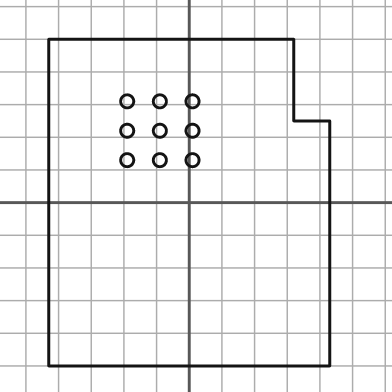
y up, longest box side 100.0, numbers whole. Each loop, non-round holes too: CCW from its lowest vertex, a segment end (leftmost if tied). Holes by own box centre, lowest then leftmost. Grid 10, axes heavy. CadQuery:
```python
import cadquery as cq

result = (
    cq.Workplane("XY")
    .moveTo(-43.0, -50.0)
    .lineTo(43.0, -50.0)
    .lineTo(43.0, 25.0)
    .lineTo(32.0, 25.0)
    .lineTo(32.0, 50.0)
    .lineTo(-43.0, 50.0)
    .close()
    .moveTo(-19.0, 13.0)
    .circle(2.0)
    .moveTo(-9.0, 13.0)
    .circle(2.0)
    .moveTo(1.0, 13.0)
    .circle(2.0)
    .moveTo(-19.0, 22.0)
    .circle(2.0)
    .moveTo(-9.0, 22.0)
    .circle(2.0)
    .moveTo(1.0, 22.0)
    .circle(2.0)
    .moveTo(-19.0, 31.0)
    .circle(2.0)
    .moveTo(-9.0, 31.0)
    .circle(2.0)
    .moveTo(1.0, 31.0)
    .circle(2.0)
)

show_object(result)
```